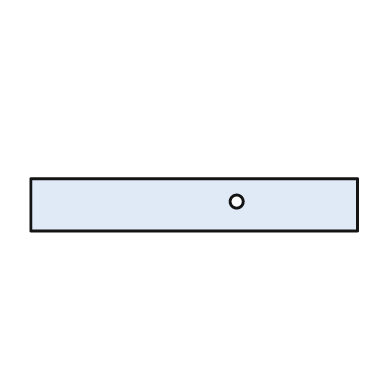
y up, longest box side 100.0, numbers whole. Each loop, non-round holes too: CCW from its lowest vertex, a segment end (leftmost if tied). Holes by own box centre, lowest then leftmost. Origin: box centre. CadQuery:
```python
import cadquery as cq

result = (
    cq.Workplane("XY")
    .moveTo(-50.0, -8.0)
    .lineTo(50.0, -8.0)
    .lineTo(50.0, 8.0)
    .lineTo(-50.0, 8.0)
    .close()
    .moveTo(13.0, 1.0)
    .circle(2.0)
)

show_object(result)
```